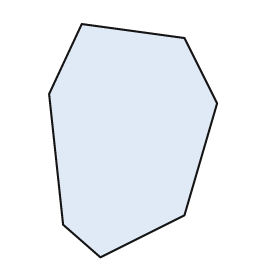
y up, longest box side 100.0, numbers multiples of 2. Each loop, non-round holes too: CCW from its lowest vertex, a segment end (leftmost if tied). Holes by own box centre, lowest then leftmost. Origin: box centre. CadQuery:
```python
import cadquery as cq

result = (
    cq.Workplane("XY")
    .moveTo(-14.0, -50.0)
    .lineTo(22.0, -32.0)
    .lineTo(36.0, 16.0)
    .lineTo(22.0, 44.0)
    .lineTo(-22.0, 50.0)
    .lineTo(-36.0, 20.0)
    .lineTo(-30.0, -36.0)
    .close()
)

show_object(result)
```